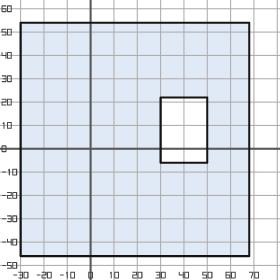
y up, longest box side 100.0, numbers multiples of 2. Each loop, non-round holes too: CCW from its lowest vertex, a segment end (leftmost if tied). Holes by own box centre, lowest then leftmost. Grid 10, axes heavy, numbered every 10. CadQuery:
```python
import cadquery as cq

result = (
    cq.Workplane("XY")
    .moveTo(-30.0, -46.0)
    .lineTo(68.0, -46.0)
    .lineTo(68.0, 54.0)
    .lineTo(-30.0, 54.0)
    .close()
    .moveTo(30.0, -6.0)
    .lineTo(50.0, -6.0)
    .lineTo(50.0, 22.0)
    .lineTo(30.0, 22.0)
    .close()
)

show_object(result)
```